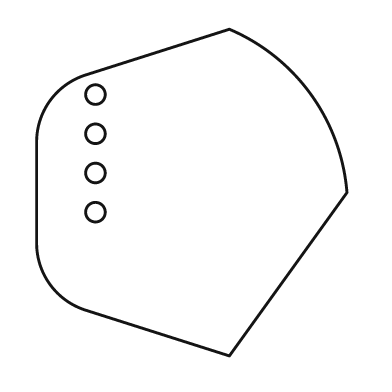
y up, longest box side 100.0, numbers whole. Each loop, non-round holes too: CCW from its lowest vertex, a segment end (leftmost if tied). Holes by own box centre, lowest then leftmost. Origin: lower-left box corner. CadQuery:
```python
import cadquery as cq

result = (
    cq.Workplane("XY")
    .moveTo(59.0, 0.0)
    .lineTo(95.0, 50.0)
    .threePointArc((84.0, 80.0), (59.0, 100.0))
    .lineTo(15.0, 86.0)
    .threePointArc((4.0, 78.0), (0.0, 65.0))
    .lineTo(0.0, 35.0)
    .threePointArc((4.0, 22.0), (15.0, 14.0))
    .close()
    .moveTo(18.0, 44.0)
    .circle(3.0)
    .moveTo(18.0, 56.0)
    .circle(3.0)
    .moveTo(18.0, 68.0)
    .circle(3.0)
    .moveTo(18.0, 80.0)
    .circle(3.0)
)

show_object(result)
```